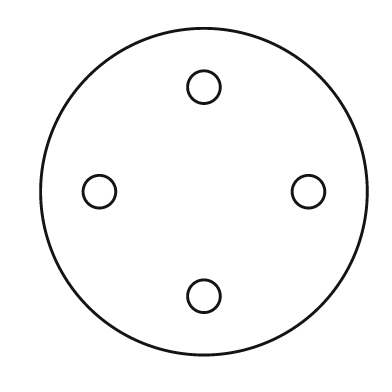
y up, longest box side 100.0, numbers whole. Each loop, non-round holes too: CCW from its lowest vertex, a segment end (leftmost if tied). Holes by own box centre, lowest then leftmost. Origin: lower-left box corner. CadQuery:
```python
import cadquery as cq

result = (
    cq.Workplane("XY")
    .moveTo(50.0, 50.0)
    .circle(50.0)
    .moveTo(50.0, 18.0)
    .circle(5.0)
    .moveTo(18.0, 50.0)
    .circle(5.0)
    .moveTo(82.0, 50.0)
    .circle(5.0)
    .moveTo(50.0, 82.0)
    .circle(5.0)
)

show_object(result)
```